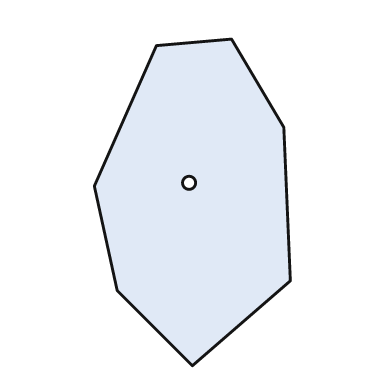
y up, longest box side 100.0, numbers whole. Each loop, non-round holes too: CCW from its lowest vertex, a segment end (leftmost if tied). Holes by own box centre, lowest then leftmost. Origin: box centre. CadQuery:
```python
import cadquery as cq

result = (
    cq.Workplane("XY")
    .moveTo(0.0, -50.0)
    .lineTo(30.0, -24.0)
    .lineTo(28.0, 23.0)
    .lineTo(12.0, 50.0)
    .lineTo(-11.0, 48.0)
    .lineTo(-30.0, 5.0)
    .lineTo(-23.0, -27.0)
    .close()
    .moveTo(-1.0, 6.0)
    .circle(2.0)
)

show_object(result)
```